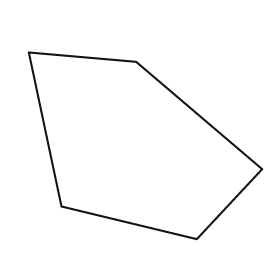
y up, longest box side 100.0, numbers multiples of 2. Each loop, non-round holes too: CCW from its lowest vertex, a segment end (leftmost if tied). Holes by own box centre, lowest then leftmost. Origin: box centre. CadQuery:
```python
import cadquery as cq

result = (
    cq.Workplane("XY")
    .moveTo(22.0, -40.0)
    .lineTo(50.0, -10.0)
    .lineTo(-4.0, 36.0)
    .lineTo(-50.0, 40.0)
    .lineTo(-36.0, -26.0)
    .close()
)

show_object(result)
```